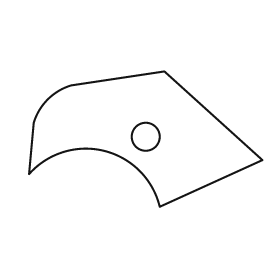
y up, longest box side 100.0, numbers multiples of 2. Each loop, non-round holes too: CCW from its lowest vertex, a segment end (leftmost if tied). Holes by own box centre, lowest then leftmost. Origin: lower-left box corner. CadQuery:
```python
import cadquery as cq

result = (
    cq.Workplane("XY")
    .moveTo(56.0, 0.0)
    .lineTo(100.0, 20.0)
    .lineTo(58.0, 58.0)
    .lineTo(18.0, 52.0)
    .threePointArc((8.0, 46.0), (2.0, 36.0))
    .lineTo(0.0, 14.0)
    .threePointArc((32.0, 24.0), (56.0, 0.0))
    .close()
    .moveTo(50.0, 30.0)
    .circle(6.0)
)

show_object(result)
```